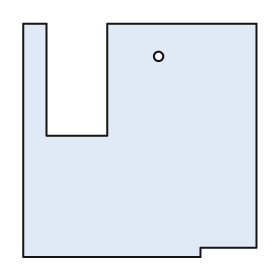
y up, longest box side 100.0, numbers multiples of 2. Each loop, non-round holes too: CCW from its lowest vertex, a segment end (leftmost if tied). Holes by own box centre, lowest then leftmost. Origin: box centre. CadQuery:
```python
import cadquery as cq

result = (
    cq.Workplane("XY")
    .moveTo(-50.0, -50.0)
    .lineTo(26.0, -50.0)
    .lineTo(26.0, -46.0)
    .lineTo(50.0, -46.0)
    .lineTo(50.0, 50.0)
    .lineTo(-14.0, 50.0)
    .lineTo(-14.0, 2.0)
    .lineTo(-40.0, 2.0)
    .lineTo(-40.0, 50.0)
    .lineTo(-50.0, 50.0)
    .close()
    .moveTo(8.0, 36.0)
    .circle(2.0)
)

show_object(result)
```